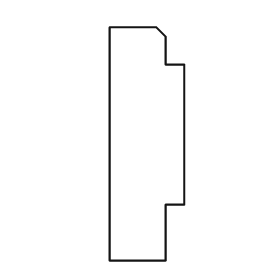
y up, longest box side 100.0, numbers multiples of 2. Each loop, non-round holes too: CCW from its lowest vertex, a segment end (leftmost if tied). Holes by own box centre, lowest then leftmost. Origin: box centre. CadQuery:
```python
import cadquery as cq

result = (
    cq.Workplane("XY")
    .moveTo(-16.0, -50.0)
    .lineTo(8.0, -50.0)
    .lineTo(8.0, -26.0)
    .lineTo(16.0, -26.0)
    .lineTo(16.0, 34.0)
    .lineTo(8.0, 34.0)
    .lineTo(8.0, 46.0)
    .lineTo(4.0, 50.0)
    .lineTo(-16.0, 50.0)
    .close()
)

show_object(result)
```